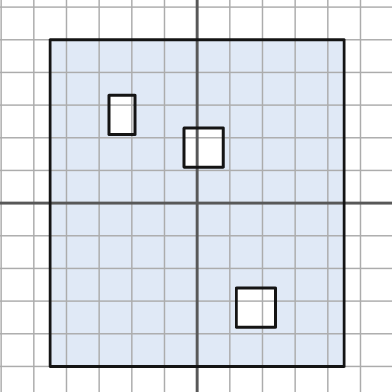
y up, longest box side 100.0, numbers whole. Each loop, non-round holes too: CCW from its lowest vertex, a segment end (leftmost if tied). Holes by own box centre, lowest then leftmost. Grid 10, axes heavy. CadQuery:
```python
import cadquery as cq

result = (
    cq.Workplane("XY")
    .moveTo(-45.0, -50.0)
    .lineTo(45.0, -50.0)
    .lineTo(45.0, 50.0)
    .lineTo(-45.0, 50.0)
    .close()
    .moveTo(12.0, -38.0)
    .lineTo(24.0, -38.0)
    .lineTo(24.0, -26.0)
    .lineTo(12.0, -26.0)
    .close()
    .moveTo(-4.0, 11.0)
    .lineTo(8.0, 11.0)
    .lineTo(8.0, 23.0)
    .lineTo(-4.0, 23.0)
    .close()
    .moveTo(-27.0, 21.0)
    .lineTo(-19.0, 21.0)
    .lineTo(-19.0, 33.0)
    .lineTo(-27.0, 33.0)
    .close()
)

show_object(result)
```